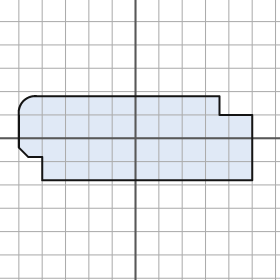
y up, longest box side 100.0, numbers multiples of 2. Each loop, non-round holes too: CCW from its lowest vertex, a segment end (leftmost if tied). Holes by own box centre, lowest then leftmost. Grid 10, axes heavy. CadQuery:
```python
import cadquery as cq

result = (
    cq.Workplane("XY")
    .moveTo(-40.0, -18.0)
    .lineTo(50.0, -18.0)
    .lineTo(50.0, 10.0)
    .lineTo(36.0, 10.0)
    .lineTo(36.0, 18.0)
    .lineTo(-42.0, 18.0)
    .threePointArc((-48.0, 16.0), (-50.0, 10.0))
    .lineTo(-50.0, -4.0)
    .lineTo(-46.0, -8.0)
    .lineTo(-40.0, -8.0)
    .close()
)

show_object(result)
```